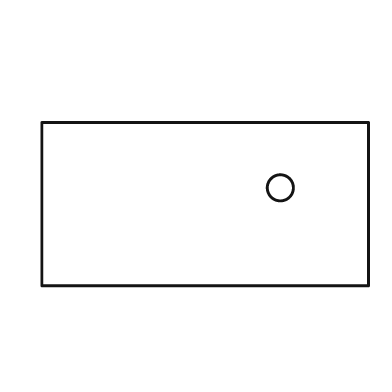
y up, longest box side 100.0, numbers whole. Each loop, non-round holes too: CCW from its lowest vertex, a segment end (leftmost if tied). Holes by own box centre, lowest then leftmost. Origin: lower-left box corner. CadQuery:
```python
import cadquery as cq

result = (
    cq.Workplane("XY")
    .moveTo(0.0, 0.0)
    .lineTo(100.0, 0.0)
    .lineTo(100.0, 50.0)
    .lineTo(0.0, 50.0)
    .close()
    .moveTo(73.0, 30.0)
    .circle(4.0)
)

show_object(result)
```